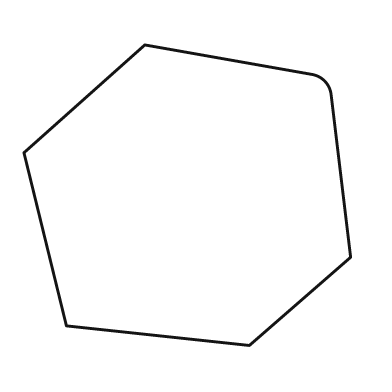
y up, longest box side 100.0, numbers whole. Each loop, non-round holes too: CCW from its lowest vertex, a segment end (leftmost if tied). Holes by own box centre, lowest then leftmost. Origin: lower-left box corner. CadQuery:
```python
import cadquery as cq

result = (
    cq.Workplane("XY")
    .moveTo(69.0, 0.0)
    .lineTo(100.0, 27.0)
    .lineTo(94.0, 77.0)
    .threePointArc((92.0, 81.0), (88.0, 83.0))
    .lineTo(37.0, 92.0)
    .lineTo(0.0, 59.0)
    .lineTo(13.0, 6.0)
    .close()
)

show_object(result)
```